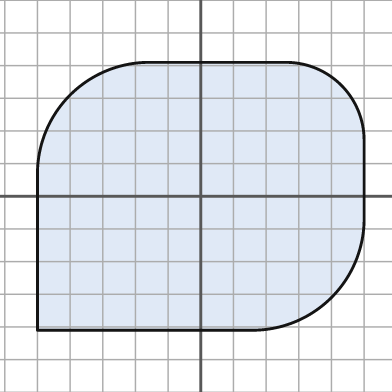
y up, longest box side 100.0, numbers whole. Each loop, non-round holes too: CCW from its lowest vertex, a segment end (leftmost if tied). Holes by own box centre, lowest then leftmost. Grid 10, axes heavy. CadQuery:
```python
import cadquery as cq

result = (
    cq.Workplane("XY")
    .moveTo(-50.0, -41.0)
    .lineTo(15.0, -41.0)
    .threePointArc((40.0, -31.0), (50.0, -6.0))
    .lineTo(50.0, 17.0)
    .threePointArc((43.0, 34.0), (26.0, 41.0))
    .lineTo(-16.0, 41.0)
    .threePointArc((-40.0, 31.0), (-50.0, 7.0))
    .close()
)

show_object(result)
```